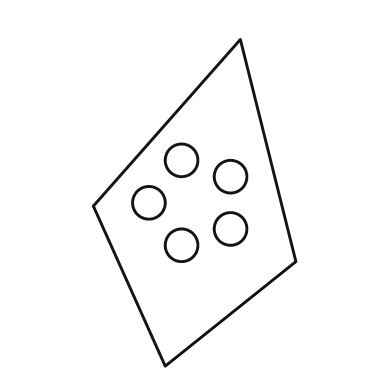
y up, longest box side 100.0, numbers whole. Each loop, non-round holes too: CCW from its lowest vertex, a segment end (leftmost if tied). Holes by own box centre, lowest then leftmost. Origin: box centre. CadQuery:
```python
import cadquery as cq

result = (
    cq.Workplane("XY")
    .moveTo(-9.0, -50.0)
    .lineTo(31.0, -18.0)
    .lineTo(14.0, 50.0)
    .lineTo(-31.0, -1.0)
    .close()
    .moveTo(-4.0, -13.0)
    .circle(5.0)
    .moveTo(11.0, -8.0)
    .circle(5.0)
    .moveTo(-14.0, 0.0)
    .circle(5.0)
    .moveTo(11.0, 8.0)
    .circle(5.0)
    .moveTo(-4.0, 13.0)
    .circle(5.0)
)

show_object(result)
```